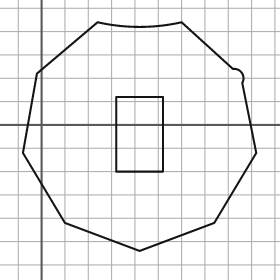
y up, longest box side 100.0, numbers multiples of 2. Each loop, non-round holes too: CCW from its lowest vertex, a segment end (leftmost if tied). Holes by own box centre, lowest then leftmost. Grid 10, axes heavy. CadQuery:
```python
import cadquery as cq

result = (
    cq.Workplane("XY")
    .moveTo(42.0, -54.0)
    .lineTo(74.0, -42.0)
    .lineTo(92.0, -12.0)
    .lineTo(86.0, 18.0)
    .threePointArc((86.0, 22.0), (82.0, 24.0))
    .lineTo(60.0, 44.0)
    .threePointArc((42.0, 42.0), (24.0, 44.0))
    .lineTo(-2.0, 22.0)
    .lineTo(-8.0, -12.0)
    .lineTo(10.0, -42.0)
    .close()
    .moveTo(32.0, -20.0)
    .lineTo(52.0, -20.0)
    .lineTo(52.0, 12.0)
    .lineTo(32.0, 12.0)
    .close()
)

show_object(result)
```